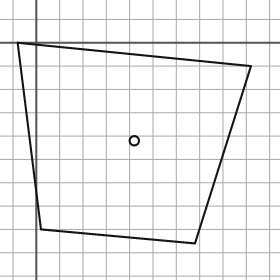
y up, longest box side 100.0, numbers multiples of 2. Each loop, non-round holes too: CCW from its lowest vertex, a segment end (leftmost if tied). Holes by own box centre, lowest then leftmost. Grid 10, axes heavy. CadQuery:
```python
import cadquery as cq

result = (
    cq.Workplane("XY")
    .moveTo(68.0, -86.0)
    .lineTo(92.0, -10.0)
    .lineTo(-8.0, 0.0)
    .lineTo(2.0, -80.0)
    .close()
    .moveTo(42.0, -42.0)
    .circle(2.0)
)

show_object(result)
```